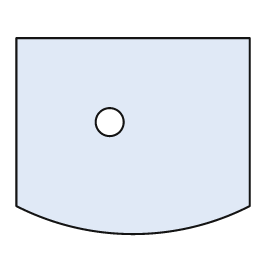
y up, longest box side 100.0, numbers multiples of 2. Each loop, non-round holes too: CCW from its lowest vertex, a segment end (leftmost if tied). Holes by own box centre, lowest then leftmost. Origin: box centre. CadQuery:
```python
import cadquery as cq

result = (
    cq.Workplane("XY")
    .moveTo(-50.0, -30.0)
    .threePointArc((0.0, -42.0), (50.0, -30.0))
    .lineTo(50.0, 42.0)
    .lineTo(-50.0, 42.0)
    .close()
    .moveTo(-10.0, 6.0)
    .circle(6.0)
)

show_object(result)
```